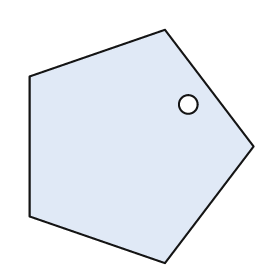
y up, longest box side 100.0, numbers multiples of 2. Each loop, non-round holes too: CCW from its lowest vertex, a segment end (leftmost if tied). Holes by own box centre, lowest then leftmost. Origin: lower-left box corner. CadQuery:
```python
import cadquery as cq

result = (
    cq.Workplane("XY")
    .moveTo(58.0, 0.0)
    .lineTo(96.0, 50.0)
    .lineTo(58.0, 100.0)
    .lineTo(0.0, 80.0)
    .lineTo(0.0, 20.0)
    .close()
    .moveTo(68.0, 68.0)
    .circle(4.0)
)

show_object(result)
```